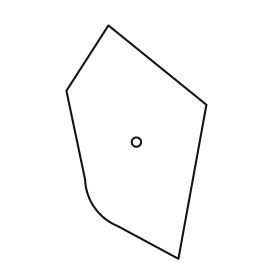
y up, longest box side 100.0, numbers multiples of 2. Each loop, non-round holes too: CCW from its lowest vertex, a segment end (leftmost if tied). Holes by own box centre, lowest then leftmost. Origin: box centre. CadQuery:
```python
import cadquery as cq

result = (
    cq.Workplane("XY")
    .moveTo(18.0, -50.0)
    .lineTo(30.0, 16.0)
    .lineTo(-12.0, 50.0)
    .lineTo(-30.0, 22.0)
    .lineTo(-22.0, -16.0)
    .threePointArc((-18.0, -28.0), (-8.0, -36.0))
    .close()
    .moveTo(0.0, 0.0)
    .circle(2.0)
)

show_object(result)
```